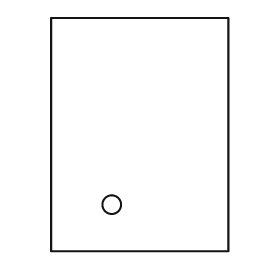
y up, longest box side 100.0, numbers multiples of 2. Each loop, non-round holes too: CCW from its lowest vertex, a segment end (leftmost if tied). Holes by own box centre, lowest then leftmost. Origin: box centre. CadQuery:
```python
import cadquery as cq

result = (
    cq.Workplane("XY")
    .moveTo(-38.0, -50.0)
    .lineTo(38.0, -50.0)
    .lineTo(38.0, 50.0)
    .lineTo(-38.0, 50.0)
    .close()
    .moveTo(-12.0, -30.0)
    .circle(4.0)
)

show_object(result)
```